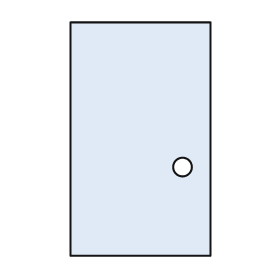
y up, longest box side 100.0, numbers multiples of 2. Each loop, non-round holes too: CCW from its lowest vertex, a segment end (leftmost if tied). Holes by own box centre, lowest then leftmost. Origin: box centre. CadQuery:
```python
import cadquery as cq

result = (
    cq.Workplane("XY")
    .moveTo(-30.0, -50.0)
    .lineTo(30.0, -50.0)
    .lineTo(30.0, 50.0)
    .lineTo(-30.0, 50.0)
    .close()
    .moveTo(18.0, -12.0)
    .circle(4.0)
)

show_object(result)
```